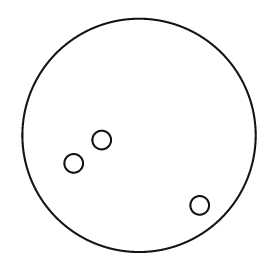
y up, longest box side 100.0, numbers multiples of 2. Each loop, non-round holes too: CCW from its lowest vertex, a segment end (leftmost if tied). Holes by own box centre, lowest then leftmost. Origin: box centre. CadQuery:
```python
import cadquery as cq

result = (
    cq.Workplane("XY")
    .moveTo(0.0, 0.0)
    .circle(50.0)
    .moveTo(26.0, -30.0)
    .circle(4.0)
    .moveTo(-28.0, -12.0)
    .circle(4.0)
    .moveTo(-16.0, -2.0)
    .circle(4.0)
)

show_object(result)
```